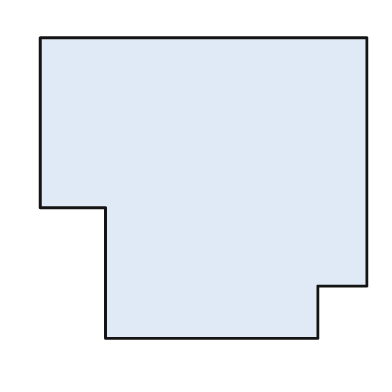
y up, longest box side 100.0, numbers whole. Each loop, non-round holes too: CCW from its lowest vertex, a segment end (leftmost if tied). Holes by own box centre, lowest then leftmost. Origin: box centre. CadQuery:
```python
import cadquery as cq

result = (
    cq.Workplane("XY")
    .moveTo(-30.0, -46.0)
    .lineTo(35.0, -46.0)
    .lineTo(35.0, -30.0)
    .lineTo(50.0, -30.0)
    .lineTo(50.0, 46.0)
    .lineTo(-50.0, 46.0)
    .lineTo(-50.0, -6.0)
    .lineTo(-30.0, -6.0)
    .close()
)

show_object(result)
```